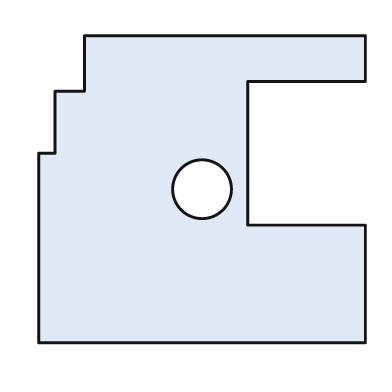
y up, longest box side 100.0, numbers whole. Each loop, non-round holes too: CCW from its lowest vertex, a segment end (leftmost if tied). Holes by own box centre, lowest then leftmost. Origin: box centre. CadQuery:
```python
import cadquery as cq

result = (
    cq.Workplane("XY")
    .moveTo(-50.0, -47.0)
    .lineTo(50.0, -47.0)
    .lineTo(50.0, -11.0)
    .lineTo(14.0, -11.0)
    .lineTo(14.0, 33.0)
    .lineTo(50.0, 33.0)
    .lineTo(50.0, 47.0)
    .lineTo(-36.0, 47.0)
    .lineTo(-36.0, 30.0)
    .lineTo(-45.0, 30.0)
    .lineTo(-45.0, 11.0)
    .lineTo(-50.0, 11.0)
    .close()
    .moveTo(0.0, 0.0)
    .circle(9.0)
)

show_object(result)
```